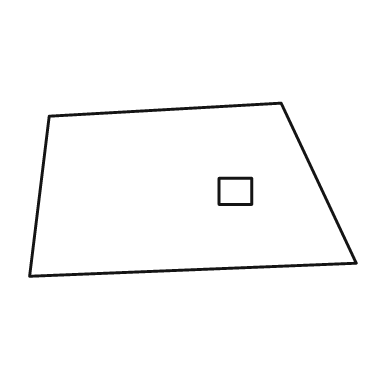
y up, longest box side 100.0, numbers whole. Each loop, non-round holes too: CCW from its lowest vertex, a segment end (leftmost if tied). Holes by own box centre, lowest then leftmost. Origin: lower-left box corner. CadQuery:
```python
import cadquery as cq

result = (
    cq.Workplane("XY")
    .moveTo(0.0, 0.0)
    .lineTo(100.0, 4.0)
    .lineTo(77.0, 53.0)
    .lineTo(6.0, 49.0)
    .close()
    .moveTo(58.0, 22.0)
    .lineTo(68.0, 22.0)
    .lineTo(68.0, 30.0)
    .lineTo(58.0, 30.0)
    .close()
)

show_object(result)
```